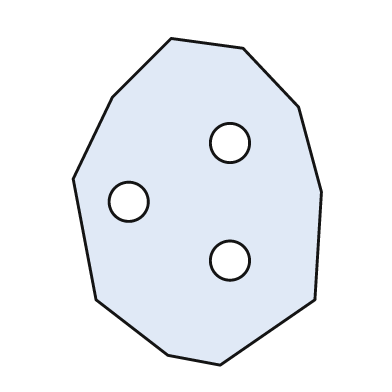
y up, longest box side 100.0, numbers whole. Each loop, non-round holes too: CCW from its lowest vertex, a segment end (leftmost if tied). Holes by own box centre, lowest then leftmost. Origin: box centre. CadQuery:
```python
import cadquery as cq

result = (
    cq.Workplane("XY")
    .moveTo(7.0, -50.0)
    .lineTo(36.0, -30.0)
    .lineTo(38.0, 3.0)
    .lineTo(31.0, 29.0)
    .lineTo(14.0, 47.0)
    .lineTo(-8.0, 50.0)
    .lineTo(-26.0, 32.0)
    .lineTo(-38.0, 7.0)
    .lineTo(-31.0, -30.0)
    .lineTo(-9.0, -47.0)
    .close()
    .moveTo(10.0, -18.0)
    .circle(6.0)
    .moveTo(-21.0, 0.0)
    .circle(6.0)
    .moveTo(10.0, 18.0)
    .circle(6.0)
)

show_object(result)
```